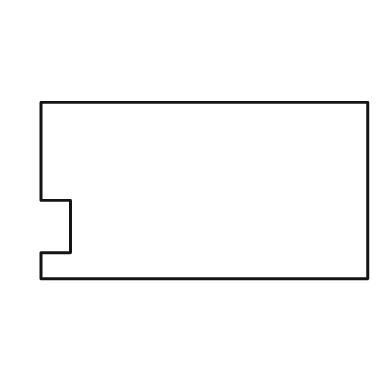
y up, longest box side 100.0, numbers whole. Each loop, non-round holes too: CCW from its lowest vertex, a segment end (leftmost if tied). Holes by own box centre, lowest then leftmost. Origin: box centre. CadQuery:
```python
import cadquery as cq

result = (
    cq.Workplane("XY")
    .moveTo(-50.0, -27.0)
    .lineTo(50.0, -27.0)
    .lineTo(50.0, 27.0)
    .lineTo(-50.0, 27.0)
    .lineTo(-50.0, -3.0)
    .lineTo(-41.0, -3.0)
    .lineTo(-41.0, -19.0)
    .lineTo(-50.0, -19.0)
    .close()
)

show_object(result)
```